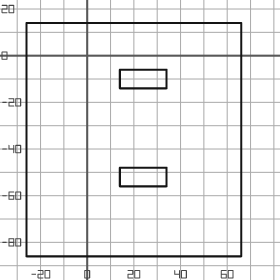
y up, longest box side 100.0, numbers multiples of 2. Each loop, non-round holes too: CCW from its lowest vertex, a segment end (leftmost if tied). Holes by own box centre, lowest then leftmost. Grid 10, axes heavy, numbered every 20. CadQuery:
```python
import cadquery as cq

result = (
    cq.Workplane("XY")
    .moveTo(-26.0, -86.0)
    .lineTo(66.0, -86.0)
    .lineTo(66.0, 14.0)
    .lineTo(-26.0, 14.0)
    .close()
    .moveTo(14.0, -56.0)
    .lineTo(34.0, -56.0)
    .lineTo(34.0, -48.0)
    .lineTo(14.0, -48.0)
    .close()
    .moveTo(14.0, -14.0)
    .lineTo(34.0, -14.0)
    .lineTo(34.0, -6.0)
    .lineTo(14.0, -6.0)
    .close()
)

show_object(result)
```